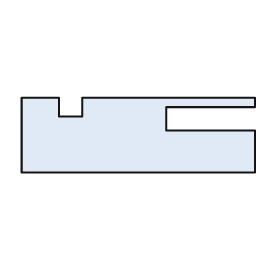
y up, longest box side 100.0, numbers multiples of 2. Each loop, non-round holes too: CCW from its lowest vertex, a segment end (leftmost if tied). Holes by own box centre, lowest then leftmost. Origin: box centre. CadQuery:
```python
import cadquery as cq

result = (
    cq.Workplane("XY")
    .moveTo(-50.0, -16.0)
    .lineTo(50.0, -16.0)
    .lineTo(50.0, 2.0)
    .lineTo(12.0, 2.0)
    .lineTo(12.0, 12.0)
    .lineTo(50.0, 12.0)
    .lineTo(50.0, 16.0)
    .lineTo(-24.0, 16.0)
    .lineTo(-24.0, 8.0)
    .lineTo(-34.0, 8.0)
    .lineTo(-34.0, 16.0)
    .lineTo(-50.0, 16.0)
    .close()
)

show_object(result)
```